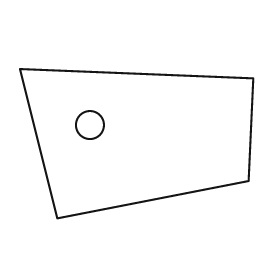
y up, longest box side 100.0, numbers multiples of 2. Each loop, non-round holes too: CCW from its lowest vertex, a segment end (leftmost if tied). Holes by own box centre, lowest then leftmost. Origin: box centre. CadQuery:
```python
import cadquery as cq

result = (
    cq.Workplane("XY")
    .moveTo(-34.0, -32.0)
    .lineTo(48.0, -16.0)
    .lineTo(50.0, 28.0)
    .lineTo(-50.0, 32.0)
    .close()
    .moveTo(-20.0, 8.0)
    .circle(6.0)
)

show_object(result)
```